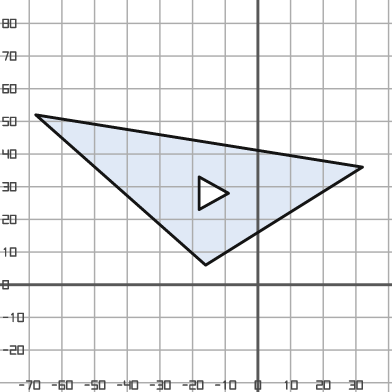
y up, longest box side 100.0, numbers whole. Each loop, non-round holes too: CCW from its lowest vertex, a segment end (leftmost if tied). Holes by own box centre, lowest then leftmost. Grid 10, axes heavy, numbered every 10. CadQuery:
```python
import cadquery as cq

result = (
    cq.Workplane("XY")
    .moveTo(-16.0, 6.0)
    .lineTo(32.0, 36.0)
    .lineTo(-68.0, 52.0)
    .close()
    .moveTo(-18.0, 23.0)
    .lineTo(-9.0, 28.0)
    .lineTo(-18.0, 33.0)
    .close()
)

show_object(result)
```